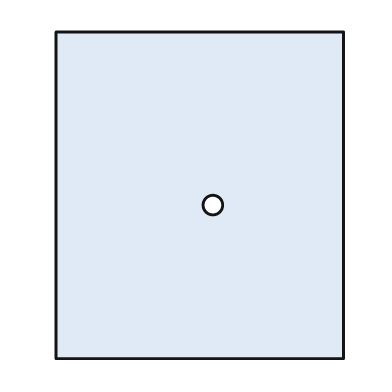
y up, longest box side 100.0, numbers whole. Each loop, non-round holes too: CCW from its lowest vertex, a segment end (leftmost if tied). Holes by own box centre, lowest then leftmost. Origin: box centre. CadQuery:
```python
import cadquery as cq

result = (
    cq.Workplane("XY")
    .moveTo(-44.0, -50.0)
    .lineTo(44.0, -50.0)
    .lineTo(44.0, 50.0)
    .lineTo(-44.0, 50.0)
    .close()
    .moveTo(4.0, -3.0)
    .circle(3.0)
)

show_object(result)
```